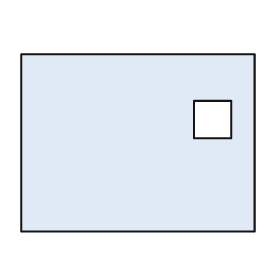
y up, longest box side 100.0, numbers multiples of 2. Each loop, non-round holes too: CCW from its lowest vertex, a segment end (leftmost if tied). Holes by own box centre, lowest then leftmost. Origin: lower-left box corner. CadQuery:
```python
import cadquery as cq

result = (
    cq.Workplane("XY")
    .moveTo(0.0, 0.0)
    .lineTo(100.0, 0.0)
    .lineTo(100.0, 76.0)
    .lineTo(0.0, 76.0)
    .close()
    .moveTo(74.0, 40.0)
    .lineTo(90.0, 40.0)
    .lineTo(90.0, 56.0)
    .lineTo(74.0, 56.0)
    .close()
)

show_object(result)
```